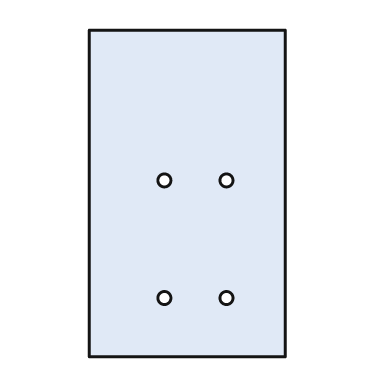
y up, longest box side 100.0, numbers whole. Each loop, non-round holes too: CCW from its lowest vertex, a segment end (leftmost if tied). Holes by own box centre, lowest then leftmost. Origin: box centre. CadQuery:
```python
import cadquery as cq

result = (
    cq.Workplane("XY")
    .moveTo(-30.0, -50.0)
    .lineTo(30.0, -50.0)
    .lineTo(30.0, 50.0)
    .lineTo(-30.0, 50.0)
    .close()
    .moveTo(-7.0, -32.0)
    .circle(2.0)
    .moveTo(12.0, -32.0)
    .circle(2.0)
    .moveTo(-7.0, 4.0)
    .circle(2.0)
    .moveTo(12.0, 4.0)
    .circle(2.0)
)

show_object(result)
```